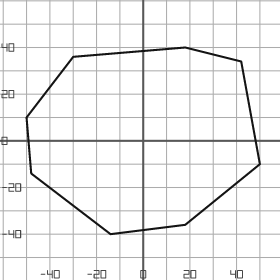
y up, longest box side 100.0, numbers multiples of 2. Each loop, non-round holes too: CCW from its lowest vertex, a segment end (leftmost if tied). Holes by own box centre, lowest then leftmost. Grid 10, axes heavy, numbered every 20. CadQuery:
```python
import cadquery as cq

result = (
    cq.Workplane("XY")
    .moveTo(-14.0, -40.0)
    .lineTo(18.0, -36.0)
    .lineTo(50.0, -10.0)
    .lineTo(42.0, 34.0)
    .lineTo(18.0, 40.0)
    .lineTo(-30.0, 36.0)
    .lineTo(-50.0, 10.0)
    .lineTo(-48.0, -14.0)
    .close()
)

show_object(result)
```